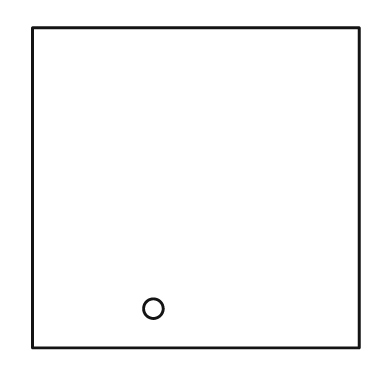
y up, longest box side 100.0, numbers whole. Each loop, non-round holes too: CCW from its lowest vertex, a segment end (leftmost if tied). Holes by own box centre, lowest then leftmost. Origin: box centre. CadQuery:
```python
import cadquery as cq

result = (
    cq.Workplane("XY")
    .moveTo(-50.0, -49.0)
    .lineTo(50.0, -49.0)
    .lineTo(50.0, 49.0)
    .lineTo(-50.0, 49.0)
    .close()
    .moveTo(-13.0, -37.0)
    .circle(3.0)
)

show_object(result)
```